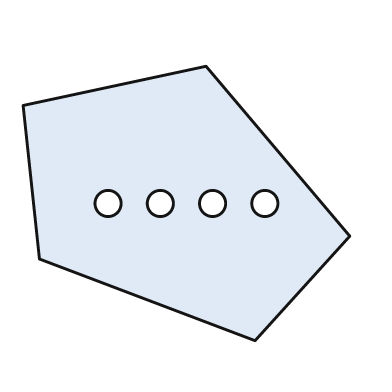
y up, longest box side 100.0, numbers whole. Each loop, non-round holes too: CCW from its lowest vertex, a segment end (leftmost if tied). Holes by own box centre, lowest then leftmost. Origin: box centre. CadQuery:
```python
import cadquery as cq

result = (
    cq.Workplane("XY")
    .moveTo(21.0, -42.0)
    .lineTo(50.0, -10.0)
    .lineTo(6.0, 42.0)
    .lineTo(-50.0, 30.0)
    .lineTo(-45.0, -17.0)
    .close()
    .moveTo(-24.0, 0.0)
    .circle(4.0)
    .moveTo(-8.0, 0.0)
    .circle(4.0)
    .moveTo(8.0, 0.0)
    .circle(4.0)
    .moveTo(24.0, 0.0)
    .circle(4.0)
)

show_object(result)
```